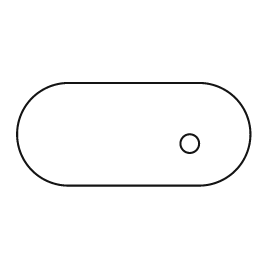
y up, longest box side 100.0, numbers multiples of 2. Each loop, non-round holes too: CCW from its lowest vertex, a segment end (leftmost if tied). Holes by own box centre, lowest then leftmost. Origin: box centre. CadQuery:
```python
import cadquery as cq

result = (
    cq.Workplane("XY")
    .moveTo(-28.0, -22.0)
    .lineTo(28.0, -22.0)
    .threePointArc((50.0, 0.0), (28.0, 22.0))
    .lineTo(-28.0, 22.0)
    .threePointArc((-50.0, 0.0), (-28.0, -22.0))
    .close()
    .moveTo(24.0, -4.0)
    .circle(4.0)
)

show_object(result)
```